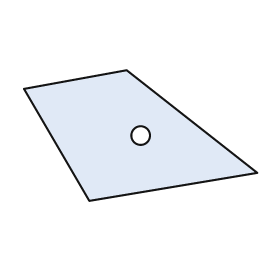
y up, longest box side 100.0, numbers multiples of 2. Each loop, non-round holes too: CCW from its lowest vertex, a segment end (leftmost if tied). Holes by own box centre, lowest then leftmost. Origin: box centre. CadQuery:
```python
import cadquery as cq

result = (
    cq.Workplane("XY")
    .moveTo(-22.0, -28.0)
    .lineTo(50.0, -16.0)
    .lineTo(-6.0, 28.0)
    .lineTo(-50.0, 20.0)
    .close()
    .moveTo(0.0, 0.0)
    .circle(4.0)
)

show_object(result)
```